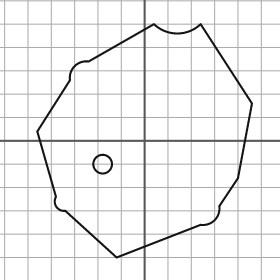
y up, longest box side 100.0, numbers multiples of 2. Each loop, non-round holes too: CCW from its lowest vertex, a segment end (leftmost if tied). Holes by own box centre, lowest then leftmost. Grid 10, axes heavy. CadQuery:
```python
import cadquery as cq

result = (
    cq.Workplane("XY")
    .moveTo(-12.0, -50.0)
    .lineTo(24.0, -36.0)
    .threePointArc((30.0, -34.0), (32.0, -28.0))
    .lineTo(40.0, -16.0)
    .lineTo(46.0, 16.0)
    .lineTo(24.0, 50.0)
    .threePointArc((14.0, 46.0), (4.0, 50.0))
    .lineTo(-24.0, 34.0)
    .threePointArc((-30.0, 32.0), (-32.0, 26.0))
    .lineTo(-46.0, 4.0)
    .lineTo(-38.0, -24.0)
    .threePointArc((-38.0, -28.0), (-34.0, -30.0))
    .close()
    .moveTo(-18.0, -10.0)
    .circle(4.0)
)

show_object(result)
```